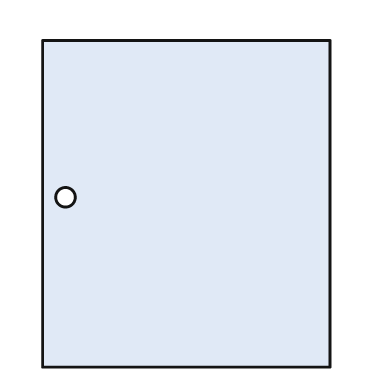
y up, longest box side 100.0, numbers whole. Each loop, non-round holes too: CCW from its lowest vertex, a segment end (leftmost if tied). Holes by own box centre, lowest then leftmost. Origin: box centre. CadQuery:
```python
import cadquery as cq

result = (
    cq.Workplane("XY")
    .moveTo(-44.0, -50.0)
    .lineTo(44.0, -50.0)
    .lineTo(44.0, 50.0)
    .lineTo(-44.0, 50.0)
    .close()
    .moveTo(-37.0, 2.0)
    .circle(3.0)
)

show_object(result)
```